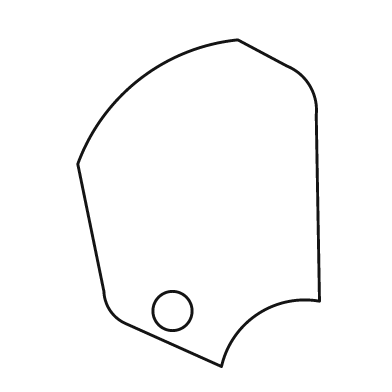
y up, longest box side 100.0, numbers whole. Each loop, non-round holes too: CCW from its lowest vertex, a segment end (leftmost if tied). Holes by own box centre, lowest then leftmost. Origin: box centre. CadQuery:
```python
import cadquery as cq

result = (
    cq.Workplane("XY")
    .moveTo(7.0, -50.0)
    .threePointArc((18.0, -34.0), (37.0, -30.0))
    .lineTo(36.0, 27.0)
    .threePointArc((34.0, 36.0), (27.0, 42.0))
    .lineTo(12.0, 50.0)
    .threePointArc((-18.0, 38.0), (-37.0, 12.0))
    .lineTo(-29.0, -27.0)
    .threePointArc((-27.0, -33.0), (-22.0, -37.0))
    .close()
    .moveTo(-8.0, -33.0)
    .circle(6.0)
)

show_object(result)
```